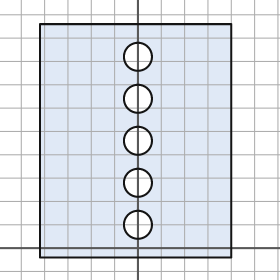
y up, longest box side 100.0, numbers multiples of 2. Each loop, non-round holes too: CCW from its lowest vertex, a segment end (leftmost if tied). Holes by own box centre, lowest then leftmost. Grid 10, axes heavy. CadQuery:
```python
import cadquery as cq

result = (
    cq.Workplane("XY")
    .moveTo(-42.0, -4.0)
    .lineTo(40.0, -4.0)
    .lineTo(40.0, 96.0)
    .lineTo(-42.0, 96.0)
    .close()
    .moveTo(0.0, 10.0)
    .circle(6.0)
    .moveTo(0.0, 28.0)
    .circle(6.0)
    .moveTo(0.0, 46.0)
    .circle(6.0)
    .moveTo(0.0, 64.0)
    .circle(6.0)
    .moveTo(0.0, 82.0)
    .circle(6.0)
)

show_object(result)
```